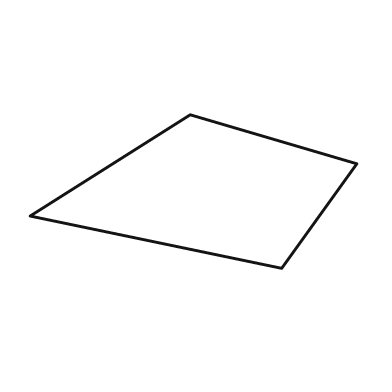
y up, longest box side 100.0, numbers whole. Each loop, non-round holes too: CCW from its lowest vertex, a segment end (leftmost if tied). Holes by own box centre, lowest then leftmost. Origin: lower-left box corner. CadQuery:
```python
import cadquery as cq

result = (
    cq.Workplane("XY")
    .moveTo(77.0, 0.0)
    .lineTo(100.0, 32.0)
    .lineTo(49.0, 47.0)
    .lineTo(0.0, 16.0)
    .close()
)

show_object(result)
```